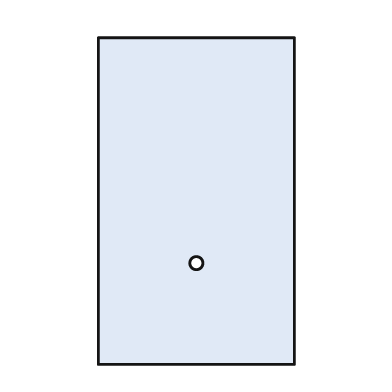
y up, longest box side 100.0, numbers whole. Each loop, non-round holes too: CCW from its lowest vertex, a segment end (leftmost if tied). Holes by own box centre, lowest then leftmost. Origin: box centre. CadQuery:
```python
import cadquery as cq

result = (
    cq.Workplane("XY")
    .moveTo(-30.0, -50.0)
    .lineTo(30.0, -50.0)
    .lineTo(30.0, 50.0)
    .lineTo(-30.0, 50.0)
    .close()
    .moveTo(0.0, -19.0)
    .circle(2.0)
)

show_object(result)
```